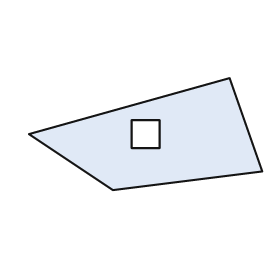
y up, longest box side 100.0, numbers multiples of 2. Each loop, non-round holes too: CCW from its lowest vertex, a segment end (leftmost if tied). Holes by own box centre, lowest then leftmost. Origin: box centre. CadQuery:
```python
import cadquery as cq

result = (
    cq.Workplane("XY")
    .moveTo(-14.0, -24.0)
    .lineTo(50.0, -16.0)
    .lineTo(36.0, 24.0)
    .lineTo(-50.0, 0.0)
    .close()
    .moveTo(-6.0, -6.0)
    .lineTo(6.0, -6.0)
    .lineTo(6.0, 6.0)
    .lineTo(-6.0, 6.0)
    .close()
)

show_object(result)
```